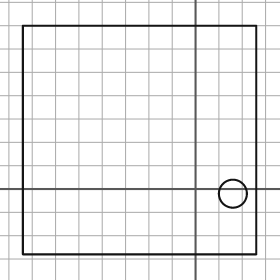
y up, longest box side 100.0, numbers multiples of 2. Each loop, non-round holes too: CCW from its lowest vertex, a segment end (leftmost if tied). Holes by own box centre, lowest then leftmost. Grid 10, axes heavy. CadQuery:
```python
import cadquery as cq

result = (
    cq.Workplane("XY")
    .moveTo(-74.0, -28.0)
    .lineTo(26.0, -28.0)
    .lineTo(26.0, 70.0)
    .lineTo(-74.0, 70.0)
    .close()
    .moveTo(16.0, -2.0)
    .circle(6.0)
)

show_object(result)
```